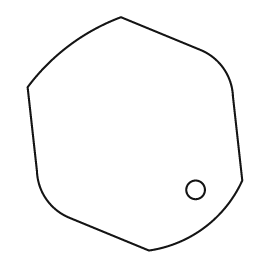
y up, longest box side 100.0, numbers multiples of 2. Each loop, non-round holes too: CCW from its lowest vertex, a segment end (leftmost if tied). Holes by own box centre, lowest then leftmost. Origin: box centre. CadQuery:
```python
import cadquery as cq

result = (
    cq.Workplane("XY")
    .moveTo(6.0, -50.0)
    .threePointArc((30.0, -40.0), (46.0, -20.0))
    .lineTo(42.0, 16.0)
    .threePointArc((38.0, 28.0), (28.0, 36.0))
    .lineTo(-6.0, 50.0)
    .threePointArc((-28.0, 38.0), (-46.0, 20.0))
    .lineTo(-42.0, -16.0)
    .threePointArc((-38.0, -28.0), (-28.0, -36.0))
    .close()
    .moveTo(26.0, -24.0)
    .circle(4.0)
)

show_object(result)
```